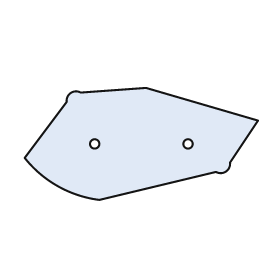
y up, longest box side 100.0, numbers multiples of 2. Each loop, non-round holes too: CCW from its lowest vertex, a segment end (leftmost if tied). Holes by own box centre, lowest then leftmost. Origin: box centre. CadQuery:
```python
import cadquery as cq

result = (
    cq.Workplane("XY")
    .moveTo(-18.0, -24.0)
    .lineTo(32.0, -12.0)
    .threePointArc((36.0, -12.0), (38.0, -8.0))
    .lineTo(50.0, 10.0)
    .lineTo(2.0, 24.0)
    .lineTo(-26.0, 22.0)
    .threePointArc((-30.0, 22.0), (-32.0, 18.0))
    .lineTo(-50.0, -6.0)
    .threePointArc((-36.0, -18.0), (-18.0, -24.0))
    .close()
    .moveTo(-20.0, 0.0)
    .circle(2.0)
    .moveTo(20.0, 0.0)
    .circle(2.0)
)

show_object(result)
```